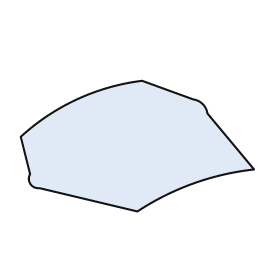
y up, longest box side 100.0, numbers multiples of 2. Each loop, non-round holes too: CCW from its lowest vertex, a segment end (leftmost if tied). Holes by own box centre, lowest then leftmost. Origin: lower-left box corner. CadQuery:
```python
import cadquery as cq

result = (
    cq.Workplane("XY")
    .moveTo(50.0, 0.0)
    .threePointArc((74.0, 12.0), (100.0, 18.0))
    .lineTo(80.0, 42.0)
    .threePointArc((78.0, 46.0), (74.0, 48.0))
    .lineTo(52.0, 56.0)
    .threePointArc((24.0, 48.0), (0.0, 32.0))
    .lineTo(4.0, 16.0)
    .threePointArc((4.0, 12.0), (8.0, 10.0))
    .close()
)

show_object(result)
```